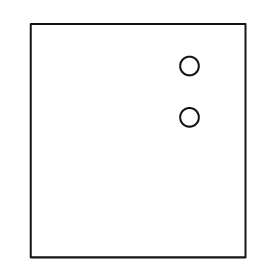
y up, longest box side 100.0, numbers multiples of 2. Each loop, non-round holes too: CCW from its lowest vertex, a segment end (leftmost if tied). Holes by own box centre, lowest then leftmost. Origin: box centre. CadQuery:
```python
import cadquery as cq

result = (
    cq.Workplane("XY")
    .moveTo(-46.0, -50.0)
    .lineTo(46.0, -50.0)
    .lineTo(46.0, 50.0)
    .lineTo(-46.0, 50.0)
    .close()
    .moveTo(22.0, 10.0)
    .circle(4.0)
    .moveTo(22.0, 32.0)
    .circle(4.0)
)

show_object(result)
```